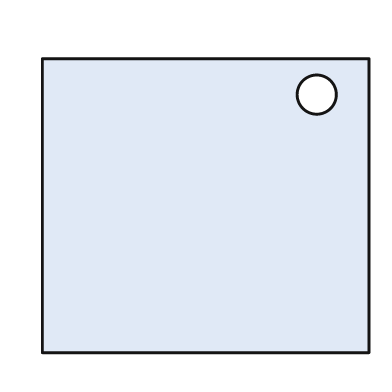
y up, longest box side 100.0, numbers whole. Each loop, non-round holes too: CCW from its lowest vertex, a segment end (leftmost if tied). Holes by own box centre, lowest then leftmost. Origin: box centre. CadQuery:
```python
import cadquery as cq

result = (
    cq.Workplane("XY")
    .moveTo(-50.0, -45.0)
    .lineTo(50.0, -45.0)
    .lineTo(50.0, 45.0)
    .lineTo(-50.0, 45.0)
    .close()
    .moveTo(34.0, 34.0)
    .circle(6.0)
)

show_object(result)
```